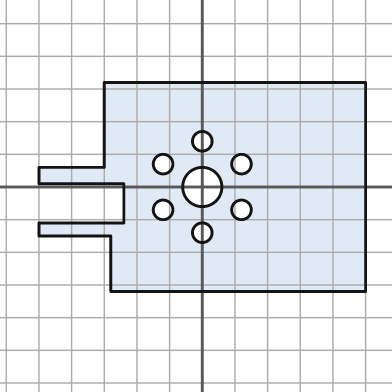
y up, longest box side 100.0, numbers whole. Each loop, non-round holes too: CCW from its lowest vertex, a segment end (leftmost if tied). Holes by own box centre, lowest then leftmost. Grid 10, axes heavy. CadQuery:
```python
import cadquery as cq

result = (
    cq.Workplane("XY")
    .moveTo(-28.0, -32.0)
    .lineTo(50.0, -32.0)
    .lineTo(50.0, 32.0)
    .lineTo(-30.0, 32.0)
    .lineTo(-30.0, 6.0)
    .lineTo(-50.0, 6.0)
    .lineTo(-50.0, 1.0)
    .lineTo(-24.0, 1.0)
    .lineTo(-24.0, -11.0)
    .lineTo(-50.0, -11.0)
    .lineTo(-50.0, -15.0)
    .lineTo(-28.0, -15.0)
    .close()
    .moveTo(0.0, -14.0)
    .circle(3.0)
    .moveTo(-12.0, -7.0)
    .circle(3.0)
    .moveTo(12.0, -7.0)
    .circle(3.0)
    .moveTo(0.0, 0.0)
    .circle(6.0)
    .moveTo(-12.0, 7.0)
    .circle(3.0)
    .moveTo(12.0, 7.0)
    .circle(3.0)
    .moveTo(0.0, 14.0)
    .circle(3.0)
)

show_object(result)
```